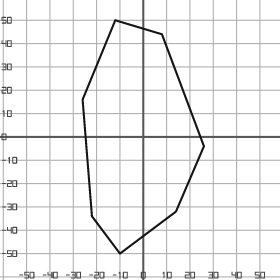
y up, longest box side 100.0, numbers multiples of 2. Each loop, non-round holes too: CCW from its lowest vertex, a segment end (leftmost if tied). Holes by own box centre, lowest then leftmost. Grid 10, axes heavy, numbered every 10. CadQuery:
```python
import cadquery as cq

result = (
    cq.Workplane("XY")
    .moveTo(-10.0, -50.0)
    .lineTo(14.0, -32.0)
    .lineTo(26.0, -4.0)
    .lineTo(8.0, 44.0)
    .lineTo(-12.0, 50.0)
    .lineTo(-26.0, 16.0)
    .lineTo(-22.0, -34.0)
    .close()
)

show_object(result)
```